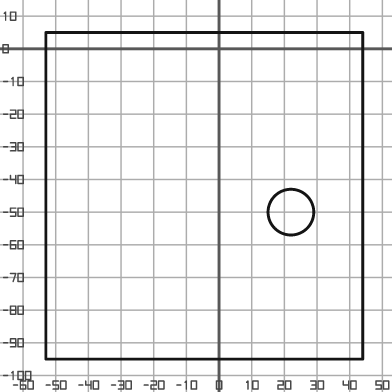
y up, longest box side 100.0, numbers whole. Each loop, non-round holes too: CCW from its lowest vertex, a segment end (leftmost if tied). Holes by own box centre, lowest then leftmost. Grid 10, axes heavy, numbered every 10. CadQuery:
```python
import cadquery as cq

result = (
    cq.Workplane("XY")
    .moveTo(-53.0, -95.0)
    .lineTo(44.0, -95.0)
    .lineTo(44.0, 5.0)
    .lineTo(-53.0, 5.0)
    .close()
    .moveTo(22.0, -50.0)
    .circle(7.0)
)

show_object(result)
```